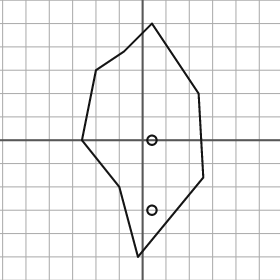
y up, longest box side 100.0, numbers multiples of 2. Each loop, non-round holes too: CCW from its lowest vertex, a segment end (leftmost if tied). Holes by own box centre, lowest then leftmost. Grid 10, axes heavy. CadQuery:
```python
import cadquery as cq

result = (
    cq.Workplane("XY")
    .moveTo(-2.0, -50.0)
    .lineTo(26.0, -16.0)
    .lineTo(24.0, 20.0)
    .lineTo(4.0, 50.0)
    .lineTo(-8.0, 38.0)
    .lineTo(-20.0, 30.0)
    .lineTo(-26.0, 0.0)
    .lineTo(-10.0, -20.0)
    .close()
    .moveTo(4.0, -30.0)
    .circle(2.0)
    .moveTo(4.0, 0.0)
    .circle(2.0)
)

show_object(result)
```